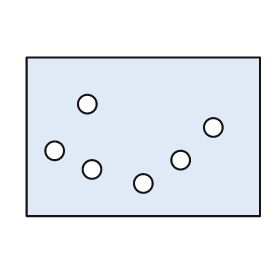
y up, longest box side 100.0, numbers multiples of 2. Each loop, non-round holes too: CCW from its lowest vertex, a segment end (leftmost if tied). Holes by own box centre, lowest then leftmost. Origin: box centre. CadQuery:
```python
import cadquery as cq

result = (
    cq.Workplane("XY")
    .moveTo(-50.0, -34.0)
    .lineTo(50.0, -34.0)
    .lineTo(50.0, 34.0)
    .lineTo(-50.0, 34.0)
    .close()
    .moveTo(0.0, -20.0)
    .circle(4.0)
    .moveTo(-22.0, -14.0)
    .circle(4.0)
    .moveTo(16.0, -10.0)
    .circle(4.0)
    .moveTo(-38.0, -6.0)
    .circle(4.0)
    .moveTo(30.0, 4.0)
    .circle(4.0)
    .moveTo(-24.0, 14.0)
    .circle(4.0)
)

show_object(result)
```